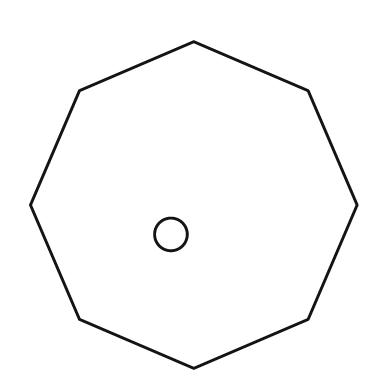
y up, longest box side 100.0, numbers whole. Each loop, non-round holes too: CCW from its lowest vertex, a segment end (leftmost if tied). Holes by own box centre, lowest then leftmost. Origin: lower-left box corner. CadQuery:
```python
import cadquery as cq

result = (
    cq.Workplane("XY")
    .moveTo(50.0, 0.0)
    .lineTo(85.0, 15.0)
    .lineTo(100.0, 50.0)
    .lineTo(85.0, 85.0)
    .lineTo(50.0, 100.0)
    .lineTo(15.0, 85.0)
    .lineTo(0.0, 50.0)
    .lineTo(15.0, 15.0)
    .close()
    .moveTo(43.0, 41.0)
    .circle(5.0)
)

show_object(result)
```